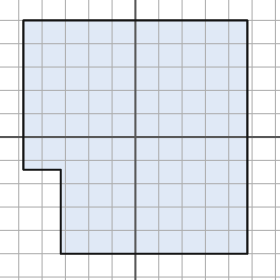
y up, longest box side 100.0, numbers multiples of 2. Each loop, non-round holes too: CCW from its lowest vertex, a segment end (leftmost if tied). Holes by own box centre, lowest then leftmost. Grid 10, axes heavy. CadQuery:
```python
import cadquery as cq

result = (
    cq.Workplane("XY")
    .moveTo(-32.0, -50.0)
    .lineTo(48.0, -50.0)
    .lineTo(48.0, 50.0)
    .lineTo(-48.0, 50.0)
    .lineTo(-48.0, -14.0)
    .lineTo(-32.0, -14.0)
    .close()
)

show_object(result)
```